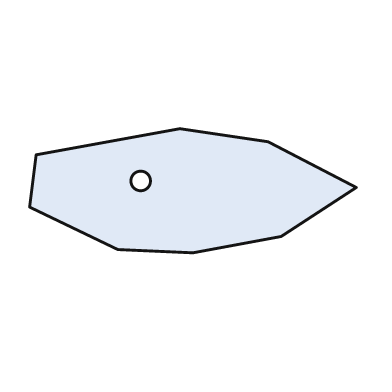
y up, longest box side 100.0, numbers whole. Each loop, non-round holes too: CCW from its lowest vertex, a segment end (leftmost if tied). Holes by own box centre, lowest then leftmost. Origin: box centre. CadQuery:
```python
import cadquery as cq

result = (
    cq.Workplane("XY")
    .moveTo(0.0, -19.0)
    .lineTo(27.0, -14.0)
    .lineTo(50.0, 1.0)
    .lineTo(23.0, 15.0)
    .lineTo(-4.0, 19.0)
    .lineTo(-48.0, 11.0)
    .lineTo(-50.0, -5.0)
    .lineTo(-23.0, -18.0)
    .close()
    .moveTo(-16.0, 3.0)
    .circle(3.0)
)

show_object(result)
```